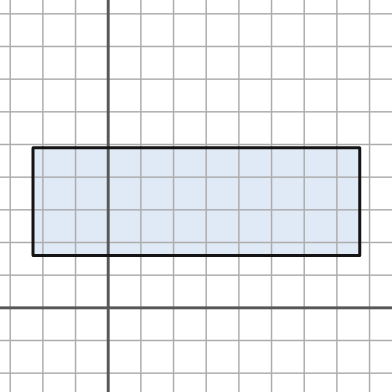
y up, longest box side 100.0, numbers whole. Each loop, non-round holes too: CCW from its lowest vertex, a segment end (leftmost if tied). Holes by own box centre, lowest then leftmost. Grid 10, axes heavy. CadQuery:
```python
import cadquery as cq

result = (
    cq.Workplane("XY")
    .moveTo(-23.0, 16.0)
    .lineTo(77.0, 16.0)
    .lineTo(77.0, 49.0)
    .lineTo(-23.0, 49.0)
    .close()
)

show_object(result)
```